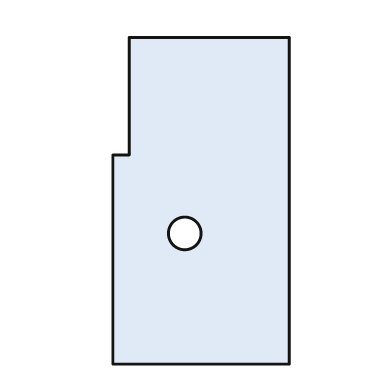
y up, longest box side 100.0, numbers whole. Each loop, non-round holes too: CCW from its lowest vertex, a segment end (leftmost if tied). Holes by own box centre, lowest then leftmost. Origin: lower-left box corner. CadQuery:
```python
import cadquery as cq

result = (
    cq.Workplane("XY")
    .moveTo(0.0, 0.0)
    .lineTo(54.0, 0.0)
    .lineTo(54.0, 100.0)
    .lineTo(5.0, 100.0)
    .lineTo(5.0, 64.0)
    .lineTo(0.0, 64.0)
    .close()
    .moveTo(22.0, 40.0)
    .circle(5.0)
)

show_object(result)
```